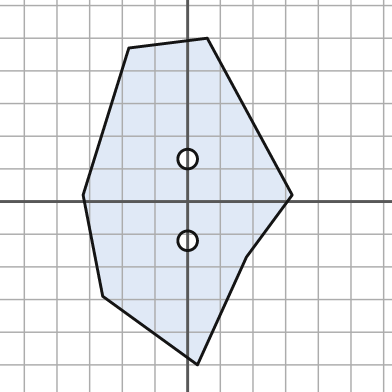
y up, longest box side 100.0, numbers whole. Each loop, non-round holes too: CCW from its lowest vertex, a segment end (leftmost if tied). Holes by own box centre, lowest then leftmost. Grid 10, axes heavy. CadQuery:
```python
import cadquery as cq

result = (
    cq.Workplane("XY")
    .moveTo(3.0, -50.0)
    .lineTo(18.0, -17.0)
    .lineTo(32.0, 2.0)
    .lineTo(6.0, 50.0)
    .lineTo(-18.0, 47.0)
    .lineTo(-32.0, 2.0)
    .lineTo(-26.0, -29.0)
    .close()
    .moveTo(0.0, -12.0)
    .circle(3.0)
    .moveTo(0.0, 13.0)
    .circle(3.0)
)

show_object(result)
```